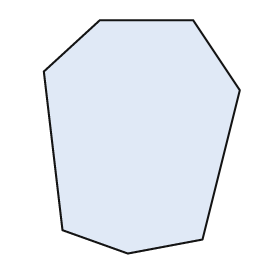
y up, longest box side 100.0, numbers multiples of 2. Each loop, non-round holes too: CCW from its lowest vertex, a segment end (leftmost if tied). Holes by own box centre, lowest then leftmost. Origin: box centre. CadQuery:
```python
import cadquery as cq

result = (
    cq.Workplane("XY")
    .moveTo(-6.0, -50.0)
    .lineTo(26.0, -44.0)
    .lineTo(42.0, 20.0)
    .lineTo(22.0, 50.0)
    .lineTo(-18.0, 50.0)
    .lineTo(-42.0, 28.0)
    .lineTo(-34.0, -40.0)
    .close()
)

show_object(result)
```